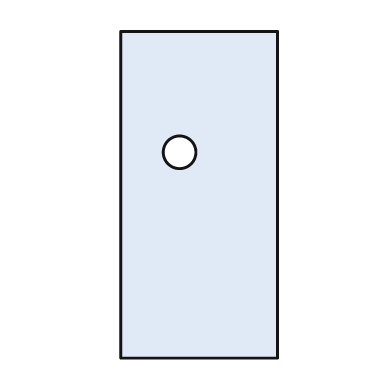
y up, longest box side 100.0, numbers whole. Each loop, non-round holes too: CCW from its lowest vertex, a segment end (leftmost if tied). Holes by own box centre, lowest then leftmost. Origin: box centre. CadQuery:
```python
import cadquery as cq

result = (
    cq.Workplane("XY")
    .moveTo(-24.0, -50.0)
    .lineTo(24.0, -50.0)
    .lineTo(24.0, 50.0)
    .lineTo(-24.0, 50.0)
    .close()
    .moveTo(-6.0, 13.0)
    .circle(5.0)
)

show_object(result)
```